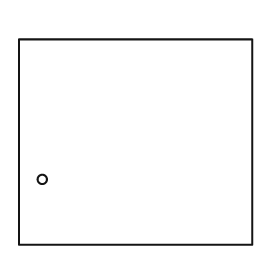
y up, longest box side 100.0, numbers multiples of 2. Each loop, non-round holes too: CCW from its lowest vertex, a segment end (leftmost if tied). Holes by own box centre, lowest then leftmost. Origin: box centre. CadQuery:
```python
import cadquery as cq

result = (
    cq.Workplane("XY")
    .moveTo(-50.0, -44.0)
    .lineTo(50.0, -44.0)
    .lineTo(50.0, 44.0)
    .lineTo(-50.0, 44.0)
    .close()
    .moveTo(-40.0, -16.0)
    .circle(2.0)
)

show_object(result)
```